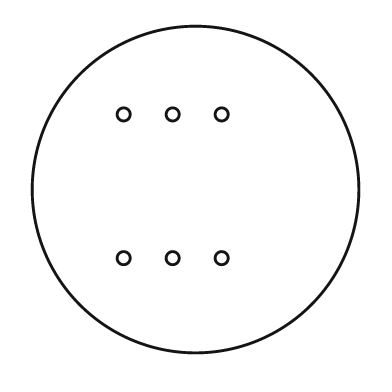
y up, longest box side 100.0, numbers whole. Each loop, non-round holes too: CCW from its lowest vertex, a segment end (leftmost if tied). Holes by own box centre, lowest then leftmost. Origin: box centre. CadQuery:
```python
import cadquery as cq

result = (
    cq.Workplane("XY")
    .moveTo(0.0, 0.0)
    .circle(50.0)
    .moveTo(-22.0, -21.0)
    .circle(2.0)
    .moveTo(-7.0, -21.0)
    .circle(2.0)
    .moveTo(8.0, -21.0)
    .circle(2.0)
    .moveTo(-22.0, 23.0)
    .circle(2.0)
    .moveTo(-7.0, 23.0)
    .circle(2.0)
    .moveTo(8.0, 23.0)
    .circle(2.0)
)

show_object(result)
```